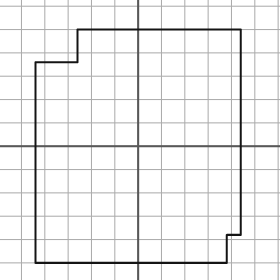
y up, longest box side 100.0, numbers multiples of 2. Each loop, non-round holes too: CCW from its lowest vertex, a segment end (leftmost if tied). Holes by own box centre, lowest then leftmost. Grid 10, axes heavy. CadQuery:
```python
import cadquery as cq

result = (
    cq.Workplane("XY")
    .moveTo(-44.0, -50.0)
    .lineTo(38.0, -50.0)
    .lineTo(38.0, -38.0)
    .lineTo(44.0, -38.0)
    .lineTo(44.0, 50.0)
    .lineTo(-26.0, 50.0)
    .lineTo(-26.0, 36.0)
    .lineTo(-44.0, 36.0)
    .close()
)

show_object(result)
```